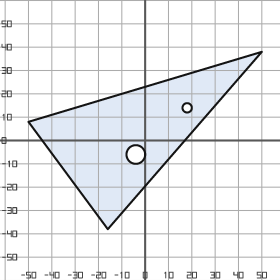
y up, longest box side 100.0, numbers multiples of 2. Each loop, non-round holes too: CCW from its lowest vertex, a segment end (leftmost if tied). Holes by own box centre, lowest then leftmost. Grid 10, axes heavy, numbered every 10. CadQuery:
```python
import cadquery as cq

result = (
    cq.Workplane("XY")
    .moveTo(-16.0, -38.0)
    .lineTo(50.0, 38.0)
    .lineTo(-50.0, 8.0)
    .close()
    .moveTo(-4.0, -6.0)
    .circle(4.0)
    .moveTo(18.0, 14.0)
    .circle(2.0)
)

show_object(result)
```